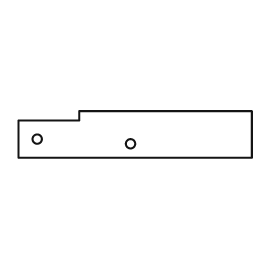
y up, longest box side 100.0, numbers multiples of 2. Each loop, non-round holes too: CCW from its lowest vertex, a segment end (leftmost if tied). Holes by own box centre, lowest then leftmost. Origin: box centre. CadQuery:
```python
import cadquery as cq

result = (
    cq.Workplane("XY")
    .moveTo(-50.0, -10.0)
    .lineTo(50.0, -10.0)
    .lineTo(50.0, 10.0)
    .lineTo(-24.0, 10.0)
    .lineTo(-24.0, 6.0)
    .lineTo(-50.0, 6.0)
    .close()
    .moveTo(-2.0, -4.0)
    .circle(2.0)
    .moveTo(-42.0, -2.0)
    .circle(2.0)
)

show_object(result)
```